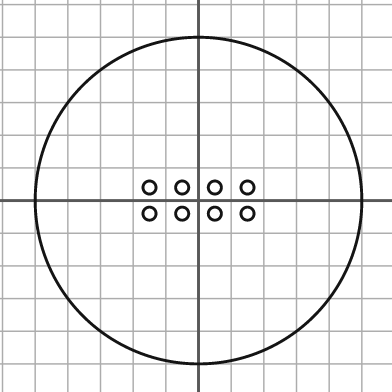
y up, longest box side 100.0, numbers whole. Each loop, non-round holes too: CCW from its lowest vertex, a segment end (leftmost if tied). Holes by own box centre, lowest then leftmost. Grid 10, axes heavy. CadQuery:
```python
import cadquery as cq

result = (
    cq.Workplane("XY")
    .moveTo(0.0, 0.0)
    .circle(50.0)
    .moveTo(-15.0, -4.0)
    .circle(2.0)
    .moveTo(-5.0, -4.0)
    .circle(2.0)
    .moveTo(5.0, -4.0)
    .circle(2.0)
    .moveTo(15.0, -4.0)
    .circle(2.0)
    .moveTo(-15.0, 4.0)
    .circle(2.0)
    .moveTo(-5.0, 4.0)
    .circle(2.0)
    .moveTo(5.0, 4.0)
    .circle(2.0)
    .moveTo(15.0, 4.0)
    .circle(2.0)
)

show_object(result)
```